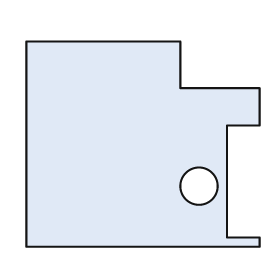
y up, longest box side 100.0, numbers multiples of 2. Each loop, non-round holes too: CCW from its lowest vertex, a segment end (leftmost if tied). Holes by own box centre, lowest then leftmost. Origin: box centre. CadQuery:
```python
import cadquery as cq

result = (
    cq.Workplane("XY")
    .moveTo(-50.0, -44.0)
    .lineTo(50.0, -44.0)
    .lineTo(50.0, -40.0)
    .lineTo(36.0, -40.0)
    .lineTo(36.0, 8.0)
    .lineTo(50.0, 8.0)
    .lineTo(50.0, 24.0)
    .lineTo(16.0, 24.0)
    .lineTo(16.0, 44.0)
    .lineTo(-50.0, 44.0)
    .close()
    .moveTo(24.0, -18.0)
    .circle(8.0)
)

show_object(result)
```